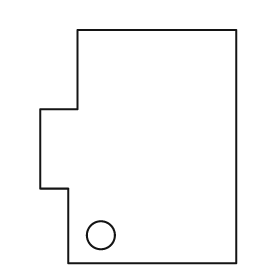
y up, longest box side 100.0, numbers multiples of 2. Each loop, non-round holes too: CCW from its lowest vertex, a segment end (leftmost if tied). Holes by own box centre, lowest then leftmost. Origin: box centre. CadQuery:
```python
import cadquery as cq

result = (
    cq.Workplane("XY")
    .moveTo(-30.0, -50.0)
    .lineTo(42.0, -50.0)
    .lineTo(42.0, 50.0)
    .lineTo(-26.0, 50.0)
    .lineTo(-26.0, 16.0)
    .lineTo(-42.0, 16.0)
    .lineTo(-42.0, -18.0)
    .lineTo(-30.0, -18.0)
    .close()
    .moveTo(-16.0, -38.0)
    .circle(6.0)
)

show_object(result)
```